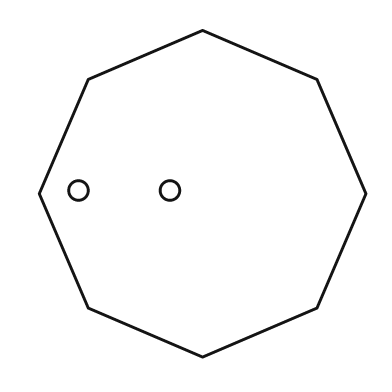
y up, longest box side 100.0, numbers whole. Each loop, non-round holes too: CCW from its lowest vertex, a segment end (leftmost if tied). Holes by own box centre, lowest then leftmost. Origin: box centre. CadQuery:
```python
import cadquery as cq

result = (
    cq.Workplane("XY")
    .moveTo(0.0, -50.0)
    .lineTo(35.0, -35.0)
    .lineTo(50.0, 0.0)
    .lineTo(35.0, 35.0)
    .lineTo(0.0, 50.0)
    .lineTo(-35.0, 35.0)
    .lineTo(-50.0, 0.0)
    .lineTo(-35.0, -35.0)
    .close()
    .moveTo(-38.0, 1.0)
    .circle(3.0)
    .moveTo(-10.0, 1.0)
    .circle(3.0)
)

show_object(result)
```